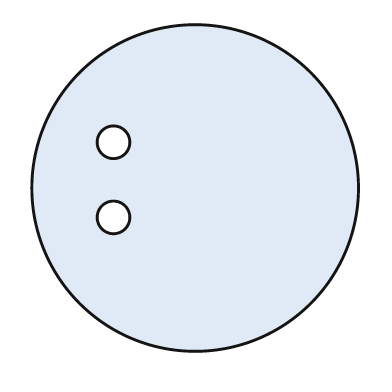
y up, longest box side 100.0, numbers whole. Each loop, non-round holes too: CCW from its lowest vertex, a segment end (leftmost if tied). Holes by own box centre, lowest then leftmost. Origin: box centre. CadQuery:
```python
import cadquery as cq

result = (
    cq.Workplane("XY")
    .moveTo(0.0, 0.0)
    .circle(50.0)
    .moveTo(-25.0, -9.0)
    .circle(5.0)
    .moveTo(-25.0, 14.0)
    .circle(5.0)
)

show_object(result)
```